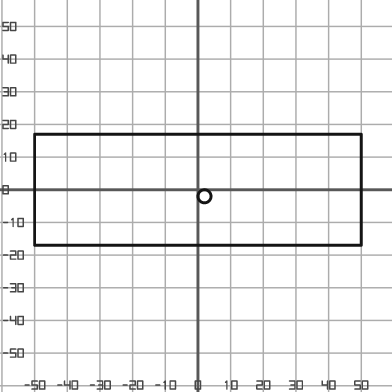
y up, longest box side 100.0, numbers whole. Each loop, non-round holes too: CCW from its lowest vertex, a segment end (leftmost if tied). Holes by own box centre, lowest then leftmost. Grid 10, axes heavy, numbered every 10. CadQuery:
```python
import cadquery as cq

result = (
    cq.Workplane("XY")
    .moveTo(-50.0, -17.0)
    .lineTo(50.0, -17.0)
    .lineTo(50.0, 17.0)
    .lineTo(-50.0, 17.0)
    .close()
    .moveTo(2.0, -2.0)
    .circle(2.0)
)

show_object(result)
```